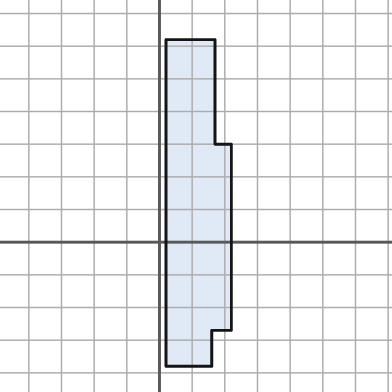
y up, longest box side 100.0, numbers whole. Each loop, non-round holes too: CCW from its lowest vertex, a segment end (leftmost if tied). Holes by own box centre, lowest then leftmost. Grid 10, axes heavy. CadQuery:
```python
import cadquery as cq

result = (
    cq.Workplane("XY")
    .moveTo(2.0, -38.0)
    .lineTo(16.0, -38.0)
    .lineTo(16.0, -27.0)
    .lineTo(22.0, -27.0)
    .lineTo(22.0, 30.0)
    .lineTo(17.0, 30.0)
    .lineTo(17.0, 62.0)
    .lineTo(2.0, 62.0)
    .close()
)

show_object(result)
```